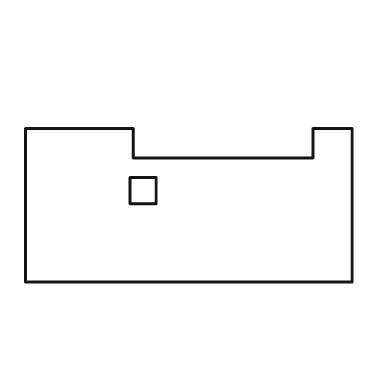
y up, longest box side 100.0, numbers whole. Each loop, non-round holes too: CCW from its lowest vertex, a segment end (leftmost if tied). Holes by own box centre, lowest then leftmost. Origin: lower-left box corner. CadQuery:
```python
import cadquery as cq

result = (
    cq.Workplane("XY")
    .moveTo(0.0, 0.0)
    .lineTo(100.0, 0.0)
    .lineTo(100.0, 47.0)
    .lineTo(88.0, 47.0)
    .lineTo(88.0, 38.0)
    .lineTo(33.0, 38.0)
    .lineTo(33.0, 47.0)
    .lineTo(0.0, 47.0)
    .close()
    .moveTo(32.0, 24.0)
    .lineTo(40.0, 24.0)
    .lineTo(40.0, 32.0)
    .lineTo(32.0, 32.0)
    .close()
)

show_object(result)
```